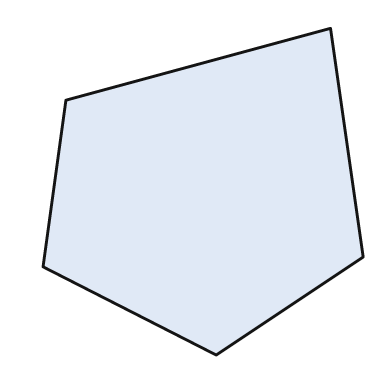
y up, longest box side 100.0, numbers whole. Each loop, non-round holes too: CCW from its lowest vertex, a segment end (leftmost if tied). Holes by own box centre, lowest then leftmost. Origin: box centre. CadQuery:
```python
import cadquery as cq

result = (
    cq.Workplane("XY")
    .moveTo(4.0, -50.0)
    .lineTo(49.0, -20.0)
    .lineTo(39.0, 50.0)
    .lineTo(-42.0, 28.0)
    .lineTo(-49.0, -23.0)
    .close()
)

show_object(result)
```